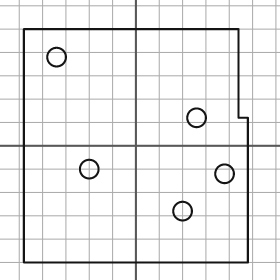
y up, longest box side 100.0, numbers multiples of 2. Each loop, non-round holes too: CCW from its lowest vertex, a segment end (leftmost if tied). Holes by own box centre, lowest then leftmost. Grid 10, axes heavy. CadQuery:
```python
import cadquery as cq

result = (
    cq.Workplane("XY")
    .moveTo(-48.0, -50.0)
    .lineTo(48.0, -50.0)
    .lineTo(48.0, 12.0)
    .lineTo(44.0, 12.0)
    .lineTo(44.0, 50.0)
    .lineTo(-48.0, 50.0)
    .close()
    .moveTo(20.0, -28.0)
    .circle(4.0)
    .moveTo(38.0, -12.0)
    .circle(4.0)
    .moveTo(-20.0, -10.0)
    .circle(4.0)
    .moveTo(26.0, 12.0)
    .circle(4.0)
    .moveTo(-34.0, 38.0)
    .circle(4.0)
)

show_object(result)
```